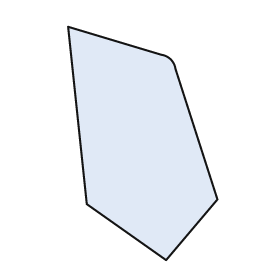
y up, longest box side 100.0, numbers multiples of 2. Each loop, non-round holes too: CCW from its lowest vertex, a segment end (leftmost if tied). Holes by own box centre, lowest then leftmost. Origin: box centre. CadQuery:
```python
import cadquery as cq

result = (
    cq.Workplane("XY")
    .moveTo(10.0, -50.0)
    .lineTo(32.0, -24.0)
    .lineTo(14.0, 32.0)
    .threePointArc((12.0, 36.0), (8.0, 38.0))
    .lineTo(-32.0, 50.0)
    .lineTo(-24.0, -26.0)
    .close()
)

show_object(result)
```